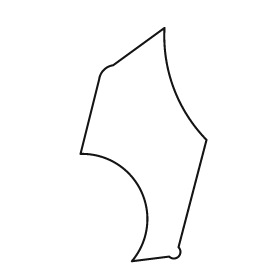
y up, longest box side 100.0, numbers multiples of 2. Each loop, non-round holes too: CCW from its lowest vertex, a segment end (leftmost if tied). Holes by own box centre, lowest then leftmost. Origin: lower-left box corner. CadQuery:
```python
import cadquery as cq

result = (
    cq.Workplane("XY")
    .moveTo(22.0, 0.0)
    .lineTo(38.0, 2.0)
    .threePointArc((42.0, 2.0), (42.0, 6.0))
    .lineTo(54.0, 52.0)
    .threePointArc((40.0, 74.0), (36.0, 100.0))
    .lineTo(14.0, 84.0)
    .threePointArc((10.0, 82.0), (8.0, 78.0))
    .lineTo(0.0, 46.0)
    .threePointArc((26.0, 30.0), (22.0, 0.0))
    .close()
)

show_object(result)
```